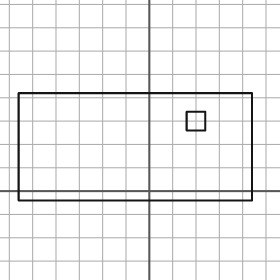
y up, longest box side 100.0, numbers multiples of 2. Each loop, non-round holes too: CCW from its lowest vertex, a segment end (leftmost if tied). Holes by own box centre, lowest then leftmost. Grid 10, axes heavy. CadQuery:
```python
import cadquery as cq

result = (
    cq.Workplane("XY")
    .moveTo(-56.0, -4.0)
    .lineTo(44.0, -4.0)
    .lineTo(44.0, 42.0)
    .lineTo(-56.0, 42.0)
    .close()
    .moveTo(16.0, 26.0)
    .lineTo(24.0, 26.0)
    .lineTo(24.0, 34.0)
    .lineTo(16.0, 34.0)
    .close()
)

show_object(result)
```